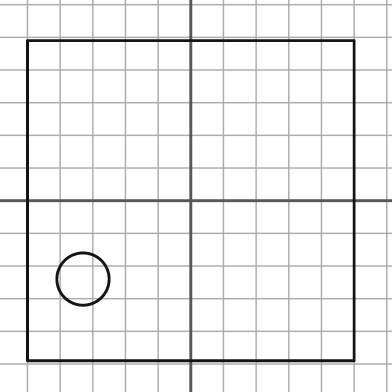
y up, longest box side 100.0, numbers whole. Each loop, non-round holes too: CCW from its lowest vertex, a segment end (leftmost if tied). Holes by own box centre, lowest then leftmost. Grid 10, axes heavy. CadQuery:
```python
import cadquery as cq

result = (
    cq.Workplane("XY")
    .moveTo(-50.0, -49.0)
    .lineTo(50.0, -49.0)
    .lineTo(50.0, 49.0)
    .lineTo(-50.0, 49.0)
    .close()
    .moveTo(-33.0, -24.0)
    .circle(8.0)
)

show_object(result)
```